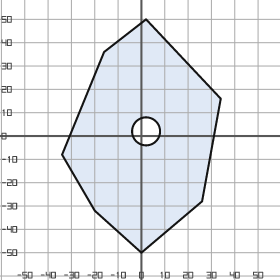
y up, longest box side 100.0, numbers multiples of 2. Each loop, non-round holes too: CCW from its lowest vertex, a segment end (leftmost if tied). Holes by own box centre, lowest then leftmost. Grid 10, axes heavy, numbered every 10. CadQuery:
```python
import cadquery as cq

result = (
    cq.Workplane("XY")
    .moveTo(0.0, -50.0)
    .lineTo(26.0, -28.0)
    .lineTo(34.0, 16.0)
    .lineTo(2.0, 50.0)
    .lineTo(-16.0, 36.0)
    .lineTo(-34.0, -8.0)
    .lineTo(-20.0, -32.0)
    .close()
    .moveTo(2.0, 2.0)
    .circle(6.0)
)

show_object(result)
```